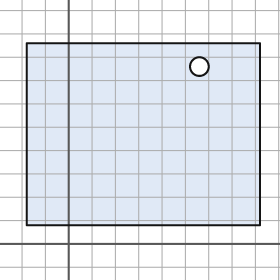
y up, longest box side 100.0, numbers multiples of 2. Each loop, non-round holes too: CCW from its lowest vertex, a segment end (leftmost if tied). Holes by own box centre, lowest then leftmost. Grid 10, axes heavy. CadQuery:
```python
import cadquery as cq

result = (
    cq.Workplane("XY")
    .moveTo(-18.0, 8.0)
    .lineTo(82.0, 8.0)
    .lineTo(82.0, 86.0)
    .lineTo(-18.0, 86.0)
    .close()
    .moveTo(56.0, 76.0)
    .circle(4.0)
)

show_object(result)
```